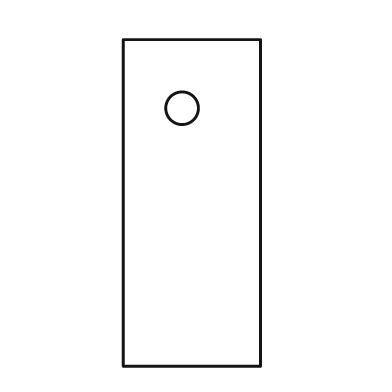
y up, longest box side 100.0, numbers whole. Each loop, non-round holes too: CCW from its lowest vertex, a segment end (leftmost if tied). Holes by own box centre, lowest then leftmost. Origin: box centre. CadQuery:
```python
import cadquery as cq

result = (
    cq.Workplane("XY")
    .moveTo(-21.0, -50.0)
    .lineTo(21.0, -50.0)
    .lineTo(21.0, 50.0)
    .lineTo(-21.0, 50.0)
    .close()
    .moveTo(-3.0, 29.0)
    .circle(5.0)
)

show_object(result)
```